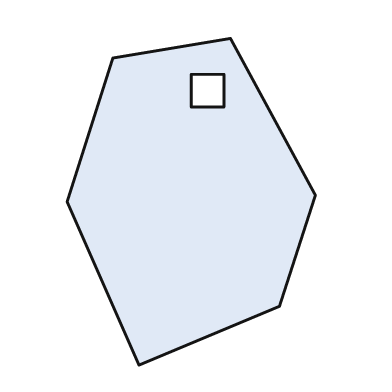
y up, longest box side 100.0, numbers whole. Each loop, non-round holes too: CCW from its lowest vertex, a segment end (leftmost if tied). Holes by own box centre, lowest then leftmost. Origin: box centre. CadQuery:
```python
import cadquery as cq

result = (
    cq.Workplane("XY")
    .moveTo(-16.0, -50.0)
    .lineTo(27.0, -32.0)
    .lineTo(38.0, 2.0)
    .lineTo(12.0, 50.0)
    .lineTo(-24.0, 44.0)
    .lineTo(-38.0, 0.0)
    .close()
    .moveTo(0.0, 29.0)
    .lineTo(10.0, 29.0)
    .lineTo(10.0, 39.0)
    .lineTo(0.0, 39.0)
    .close()
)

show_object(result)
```